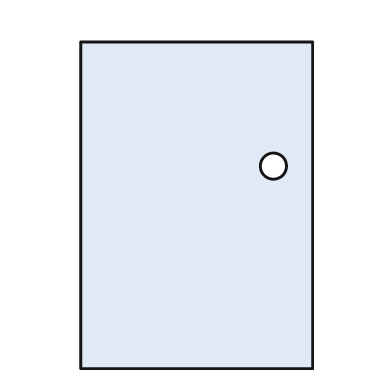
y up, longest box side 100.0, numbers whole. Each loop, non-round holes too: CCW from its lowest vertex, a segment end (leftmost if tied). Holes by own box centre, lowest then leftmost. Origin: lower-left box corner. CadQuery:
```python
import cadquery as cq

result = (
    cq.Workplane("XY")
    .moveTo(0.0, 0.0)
    .lineTo(71.0, 0.0)
    .lineTo(71.0, 100.0)
    .lineTo(0.0, 100.0)
    .close()
    .moveTo(59.0, 62.0)
    .circle(4.0)
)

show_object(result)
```